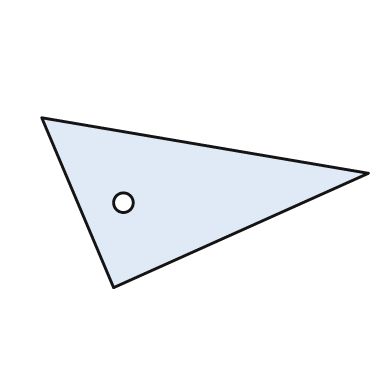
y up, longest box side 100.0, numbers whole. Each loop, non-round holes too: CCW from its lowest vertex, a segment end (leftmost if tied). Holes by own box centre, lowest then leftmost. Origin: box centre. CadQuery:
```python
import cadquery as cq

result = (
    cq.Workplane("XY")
    .moveTo(-28.0, -26.0)
    .lineTo(50.0, 9.0)
    .lineTo(-50.0, 26.0)
    .close()
    .moveTo(-25.0, 0.0)
    .circle(3.0)
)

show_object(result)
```